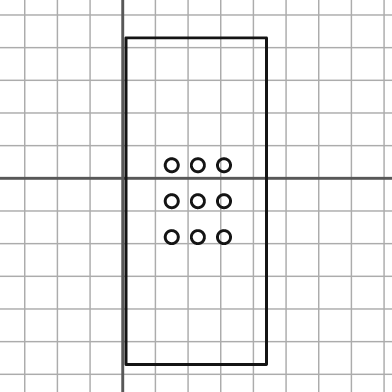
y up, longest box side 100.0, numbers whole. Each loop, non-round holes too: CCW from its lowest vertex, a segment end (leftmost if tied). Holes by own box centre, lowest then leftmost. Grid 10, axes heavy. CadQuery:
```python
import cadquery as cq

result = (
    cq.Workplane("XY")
    .moveTo(1.0, -57.0)
    .lineTo(44.0, -57.0)
    .lineTo(44.0, 43.0)
    .lineTo(1.0, 43.0)
    .close()
    .moveTo(15.0, -18.0)
    .circle(2.0)
    .moveTo(23.0, -18.0)
    .circle(2.0)
    .moveTo(31.0, -18.0)
    .circle(2.0)
    .moveTo(15.0, -7.0)
    .circle(2.0)
    .moveTo(23.0, -7.0)
    .circle(2.0)
    .moveTo(31.0, -7.0)
    .circle(2.0)
    .moveTo(15.0, 4.0)
    .circle(2.0)
    .moveTo(23.0, 4.0)
    .circle(2.0)
    .moveTo(31.0, 4.0)
    .circle(2.0)
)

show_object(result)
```